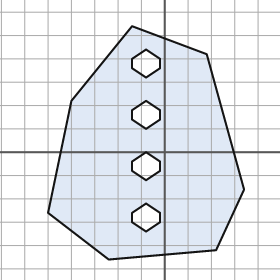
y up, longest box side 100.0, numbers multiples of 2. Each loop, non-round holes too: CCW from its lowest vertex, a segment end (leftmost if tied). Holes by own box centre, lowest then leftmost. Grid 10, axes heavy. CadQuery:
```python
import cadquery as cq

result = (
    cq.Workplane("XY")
    .moveTo(-24.0, -46.0)
    .lineTo(22.0, -42.0)
    .lineTo(34.0, -16.0)
    .lineTo(18.0, 42.0)
    .lineTo(-14.0, 54.0)
    .lineTo(-40.0, 22.0)
    .lineTo(-50.0, -26.0)
    .close()
    .moveTo(-8.0, -34.0)
    .lineTo(-2.0, -30.0)
    .lineTo(-2.0, -26.0)
    .lineTo(-8.0, -22.0)
    .lineTo(-14.0, -26.0)
    .lineTo(-14.0, -30.0)
    .close()
    .moveTo(-8.0, -12.0)
    .lineTo(-2.0, -8.0)
    .lineTo(-2.0, -4.0)
    .lineTo(-8.0, 0.0)
    .lineTo(-14.0, -4.0)
    .lineTo(-14.0, -8.0)
    .close()
    .moveTo(-8.0, 10.0)
    .lineTo(-2.0, 14.0)
    .lineTo(-2.0, 18.0)
    .lineTo(-8.0, 22.0)
    .lineTo(-14.0, 18.0)
    .lineTo(-14.0, 14.0)
    .close()
    .moveTo(-8.0, 32.0)
    .lineTo(-2.0, 36.0)
    .lineTo(-2.0, 40.0)
    .lineTo(-8.0, 44.0)
    .lineTo(-14.0, 40.0)
    .lineTo(-14.0, 36.0)
    .close()
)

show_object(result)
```